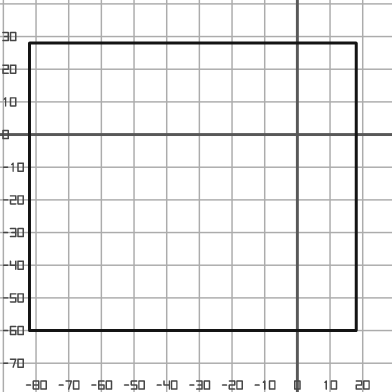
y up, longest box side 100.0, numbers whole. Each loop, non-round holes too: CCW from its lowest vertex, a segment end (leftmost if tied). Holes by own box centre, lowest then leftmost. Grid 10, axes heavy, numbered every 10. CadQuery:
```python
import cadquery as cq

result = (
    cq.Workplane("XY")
    .moveTo(-82.0, -60.0)
    .lineTo(18.0, -60.0)
    .lineTo(18.0, 28.0)
    .lineTo(-82.0, 28.0)
    .close()
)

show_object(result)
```